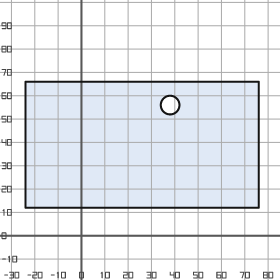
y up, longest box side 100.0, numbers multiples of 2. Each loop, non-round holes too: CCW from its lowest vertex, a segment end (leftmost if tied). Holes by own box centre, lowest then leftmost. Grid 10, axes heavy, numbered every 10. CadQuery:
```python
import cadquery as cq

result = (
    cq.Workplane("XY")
    .moveTo(-24.0, 12.0)
    .lineTo(76.0, 12.0)
    .lineTo(76.0, 66.0)
    .lineTo(-24.0, 66.0)
    .close()
    .moveTo(38.0, 56.0)
    .circle(4.0)
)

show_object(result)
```